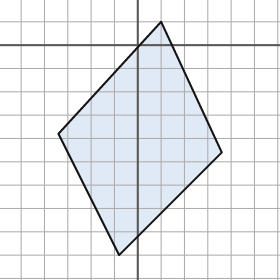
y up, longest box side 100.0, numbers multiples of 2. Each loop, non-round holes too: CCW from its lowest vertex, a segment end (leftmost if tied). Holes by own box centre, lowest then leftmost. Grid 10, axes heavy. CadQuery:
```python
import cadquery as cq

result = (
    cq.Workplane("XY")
    .moveTo(-8.0, -90.0)
    .lineTo(36.0, -46.0)
    .lineTo(10.0, 10.0)
    .lineTo(-34.0, -38.0)
    .close()
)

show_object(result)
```